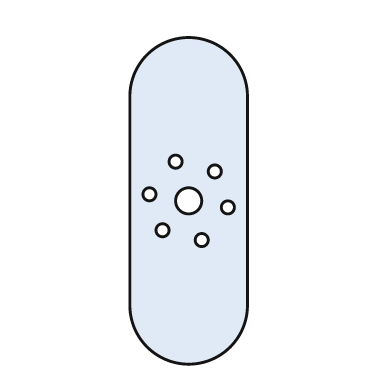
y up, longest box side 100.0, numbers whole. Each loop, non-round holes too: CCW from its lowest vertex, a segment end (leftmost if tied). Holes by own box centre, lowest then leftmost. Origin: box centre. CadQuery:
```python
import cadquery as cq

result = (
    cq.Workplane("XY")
    .moveTo(-18.0, -32.0)
    .threePointArc((0.0, -50.0), (18.0, -32.0))
    .lineTo(18.0, 32.0)
    .threePointArc((0.0, 50.0), (-18.0, 32.0))
    .close()
    .moveTo(4.0, -12.0)
    .circle(2.0)
    .moveTo(-8.0, -9.0)
    .circle(2.0)
    .moveTo(12.0, -2.0)
    .circle(2.0)
    .moveTo(0.0, 0.0)
    .circle(4.0)
    .moveTo(-12.0, 2.0)
    .circle(2.0)
    .moveTo(8.0, 9.0)
    .circle(2.0)
    .moveTo(-4.0, 12.0)
    .circle(2.0)
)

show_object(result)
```